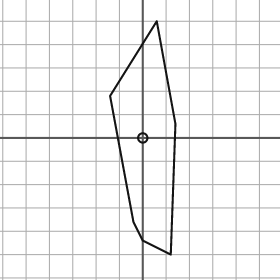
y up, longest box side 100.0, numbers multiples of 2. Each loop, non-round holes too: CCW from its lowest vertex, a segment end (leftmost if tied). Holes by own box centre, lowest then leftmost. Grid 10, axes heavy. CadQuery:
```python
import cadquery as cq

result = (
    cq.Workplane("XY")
    .moveTo(12.0, -50.0)
    .lineTo(14.0, 6.0)
    .lineTo(6.0, 50.0)
    .lineTo(-14.0, 18.0)
    .lineTo(-4.0, -36.0)
    .lineTo(0.0, -44.0)
    .close()
    .moveTo(0.0, 0.0)
    .circle(2.0)
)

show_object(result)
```